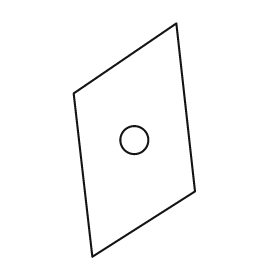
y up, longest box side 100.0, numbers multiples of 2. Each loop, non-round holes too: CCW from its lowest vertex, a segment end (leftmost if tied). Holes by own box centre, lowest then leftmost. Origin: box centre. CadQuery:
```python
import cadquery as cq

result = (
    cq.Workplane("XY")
    .moveTo(-18.0, -50.0)
    .lineTo(26.0, -22.0)
    .lineTo(18.0, 50.0)
    .lineTo(-26.0, 20.0)
    .close()
    .moveTo(0.0, 0.0)
    .circle(6.0)
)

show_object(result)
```